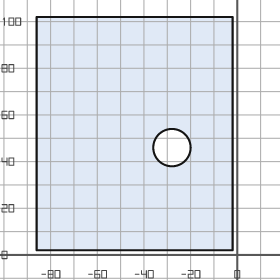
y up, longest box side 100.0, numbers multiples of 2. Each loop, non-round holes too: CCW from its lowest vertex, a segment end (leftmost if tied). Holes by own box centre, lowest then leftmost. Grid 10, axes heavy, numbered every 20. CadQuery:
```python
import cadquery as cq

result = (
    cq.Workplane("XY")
    .moveTo(-86.0, 2.0)
    .lineTo(-2.0, 2.0)
    .lineTo(-2.0, 102.0)
    .lineTo(-86.0, 102.0)
    .close()
    .moveTo(-28.0, 46.0)
    .circle(8.0)
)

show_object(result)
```